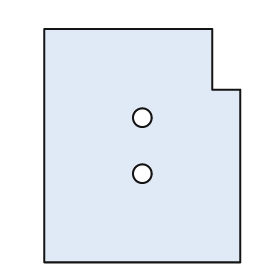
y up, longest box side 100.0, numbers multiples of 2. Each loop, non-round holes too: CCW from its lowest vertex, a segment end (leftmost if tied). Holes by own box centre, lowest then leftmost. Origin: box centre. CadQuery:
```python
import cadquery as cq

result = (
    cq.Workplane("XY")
    .moveTo(-42.0, -50.0)
    .lineTo(42.0, -50.0)
    .lineTo(42.0, 24.0)
    .lineTo(30.0, 24.0)
    .lineTo(30.0, 50.0)
    .lineTo(-42.0, 50.0)
    .close()
    .moveTo(0.0, -12.0)
    .circle(4.0)
    .moveTo(0.0, 12.0)
    .circle(4.0)
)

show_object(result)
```